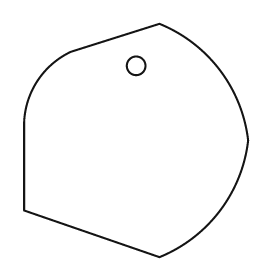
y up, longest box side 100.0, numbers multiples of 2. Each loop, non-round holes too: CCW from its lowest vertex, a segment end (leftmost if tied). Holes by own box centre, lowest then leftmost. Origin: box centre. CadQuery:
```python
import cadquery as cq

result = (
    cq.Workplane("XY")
    .moveTo(10.0, -50.0)
    .threePointArc((36.0, -30.0), (48.0, 0.0))
    .threePointArc((36.0, 30.0), (10.0, 50.0))
    .lineTo(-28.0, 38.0)
    .threePointArc((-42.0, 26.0), (-48.0, 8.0))
    .lineTo(-48.0, -30.0)
    .close()
    .moveTo(0.0, 32.0)
    .circle(4.0)
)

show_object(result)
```